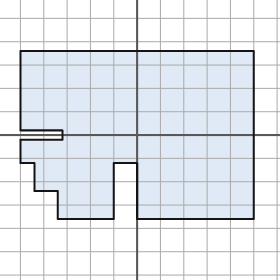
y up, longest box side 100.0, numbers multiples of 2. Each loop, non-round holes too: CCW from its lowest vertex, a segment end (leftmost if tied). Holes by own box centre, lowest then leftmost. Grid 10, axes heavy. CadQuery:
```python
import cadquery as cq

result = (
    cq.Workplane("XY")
    .moveTo(-34.0, -36.0)
    .lineTo(-10.0, -36.0)
    .lineTo(-10.0, -12.0)
    .lineTo(0.0, -12.0)
    .lineTo(0.0, -36.0)
    .lineTo(50.0, -36.0)
    .lineTo(50.0, 36.0)
    .lineTo(-50.0, 36.0)
    .lineTo(-50.0, 2.0)
    .lineTo(-32.0, 2.0)
    .lineTo(-32.0, -2.0)
    .lineTo(-50.0, -2.0)
    .lineTo(-50.0, -12.0)
    .lineTo(-44.0, -12.0)
    .lineTo(-44.0, -24.0)
    .lineTo(-34.0, -24.0)
    .close()
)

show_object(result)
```